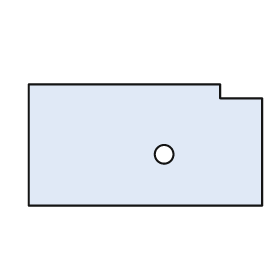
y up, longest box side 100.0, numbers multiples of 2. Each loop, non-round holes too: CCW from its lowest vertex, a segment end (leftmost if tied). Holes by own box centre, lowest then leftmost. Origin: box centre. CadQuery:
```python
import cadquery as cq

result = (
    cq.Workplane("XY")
    .moveTo(-50.0, -26.0)
    .lineTo(50.0, -26.0)
    .lineTo(50.0, 20.0)
    .lineTo(32.0, 20.0)
    .lineTo(32.0, 26.0)
    .lineTo(-50.0, 26.0)
    .close()
    .moveTo(8.0, -4.0)
    .circle(4.0)
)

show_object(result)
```